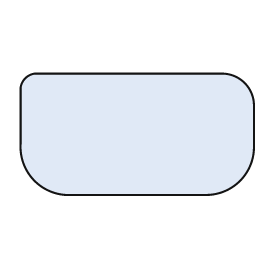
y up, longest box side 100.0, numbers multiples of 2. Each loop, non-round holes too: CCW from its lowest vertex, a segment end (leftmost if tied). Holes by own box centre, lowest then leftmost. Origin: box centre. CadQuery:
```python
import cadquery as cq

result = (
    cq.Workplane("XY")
    .moveTo(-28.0, -26.0)
    .lineTo(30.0, -26.0)
    .threePointArc((44.0, -20.0), (50.0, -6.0))
    .lineTo(50.0, 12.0)
    .threePointArc((46.0, 22.0), (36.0, 26.0))
    .lineTo(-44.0, 26.0)
    .threePointArc((-48.0, 24.0), (-50.0, 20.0))
    .lineTo(-50.0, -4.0)
    .threePointArc((-44.0, -20.0), (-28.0, -26.0))
    .close()
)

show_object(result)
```